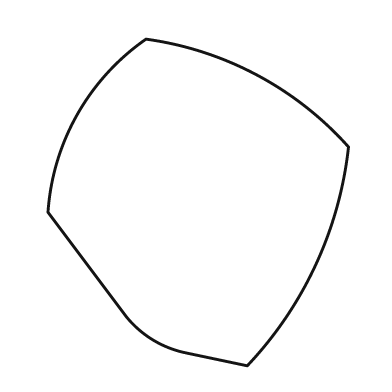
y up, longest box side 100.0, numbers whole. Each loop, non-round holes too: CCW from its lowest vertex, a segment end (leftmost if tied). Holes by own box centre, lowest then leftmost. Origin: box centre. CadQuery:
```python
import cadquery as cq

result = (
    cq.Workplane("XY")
    .moveTo(15.0, -50.0)
    .threePointArc((36.0, -19.0), (46.0, 17.0))
    .threePointArc((18.0, 39.0), (-16.0, 50.0))
    .threePointArc((-37.0, 27.0), (-46.0, -3.0))
    .lineTo(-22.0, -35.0)
    .threePointArc((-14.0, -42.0), (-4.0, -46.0))
    .close()
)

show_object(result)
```